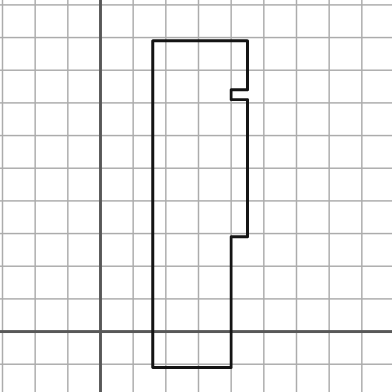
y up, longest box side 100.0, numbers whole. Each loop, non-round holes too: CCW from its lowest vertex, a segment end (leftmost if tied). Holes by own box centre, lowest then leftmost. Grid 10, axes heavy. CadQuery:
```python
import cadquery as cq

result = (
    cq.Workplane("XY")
    .moveTo(16.0, -11.0)
    .lineTo(40.0, -11.0)
    .lineTo(40.0, 29.0)
    .lineTo(45.0, 29.0)
    .lineTo(45.0, 71.0)
    .lineTo(40.0, 71.0)
    .lineTo(40.0, 74.0)
    .lineTo(45.0, 74.0)
    .lineTo(45.0, 89.0)
    .lineTo(16.0, 89.0)
    .close()
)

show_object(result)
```